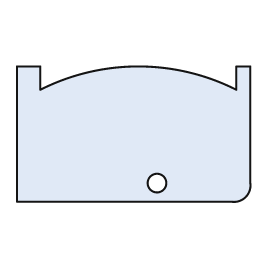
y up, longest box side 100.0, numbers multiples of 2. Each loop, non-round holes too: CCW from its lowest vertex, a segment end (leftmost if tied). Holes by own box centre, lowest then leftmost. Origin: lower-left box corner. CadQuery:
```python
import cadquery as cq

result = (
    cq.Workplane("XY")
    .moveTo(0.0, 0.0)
    .lineTo(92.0, 0.0)
    .threePointArc((98.0, 2.0), (100.0, 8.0))
    .lineTo(100.0, 58.0)
    .lineTo(94.0, 58.0)
    .lineTo(94.0, 48.0)
    .threePointArc((52.0, 58.0), (10.0, 48.0))
    .lineTo(10.0, 58.0)
    .lineTo(0.0, 58.0)
    .close()
    .moveTo(60.0, 8.0)
    .circle(4.0)
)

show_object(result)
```